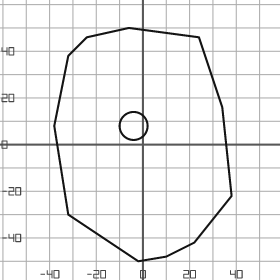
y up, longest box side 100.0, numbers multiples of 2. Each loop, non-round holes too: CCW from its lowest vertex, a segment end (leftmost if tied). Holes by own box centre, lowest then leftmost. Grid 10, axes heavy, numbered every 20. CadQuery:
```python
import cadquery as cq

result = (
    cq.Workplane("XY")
    .moveTo(-2.0, -50.0)
    .lineTo(10.0, -48.0)
    .lineTo(22.0, -42.0)
    .lineTo(38.0, -22.0)
    .lineTo(34.0, 16.0)
    .lineTo(24.0, 46.0)
    .lineTo(-6.0, 50.0)
    .lineTo(-24.0, 46.0)
    .lineTo(-32.0, 38.0)
    .lineTo(-38.0, 8.0)
    .lineTo(-32.0, -30.0)
    .close()
    .moveTo(-4.0, 8.0)
    .circle(6.0)
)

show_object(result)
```